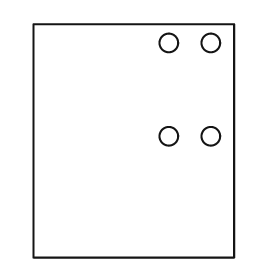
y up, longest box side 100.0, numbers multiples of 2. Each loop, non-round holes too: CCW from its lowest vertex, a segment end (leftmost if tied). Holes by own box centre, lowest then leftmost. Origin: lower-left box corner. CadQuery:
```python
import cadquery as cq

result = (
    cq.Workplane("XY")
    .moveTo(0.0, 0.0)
    .lineTo(86.0, 0.0)
    .lineTo(86.0, 100.0)
    .lineTo(0.0, 100.0)
    .close()
    .moveTo(58.0, 52.0)
    .circle(4.0)
    .moveTo(76.0, 52.0)
    .circle(4.0)
    .moveTo(58.0, 92.0)
    .circle(4.0)
    .moveTo(76.0, 92.0)
    .circle(4.0)
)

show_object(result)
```